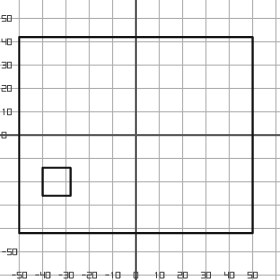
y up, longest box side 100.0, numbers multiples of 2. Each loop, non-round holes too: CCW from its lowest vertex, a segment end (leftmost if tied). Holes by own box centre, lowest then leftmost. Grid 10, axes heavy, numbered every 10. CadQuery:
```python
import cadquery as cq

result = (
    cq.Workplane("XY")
    .moveTo(-50.0, -42.0)
    .lineTo(50.0, -42.0)
    .lineTo(50.0, 42.0)
    .lineTo(-50.0, 42.0)
    .close()
    .moveTo(-40.0, -26.0)
    .lineTo(-28.0, -26.0)
    .lineTo(-28.0, -14.0)
    .lineTo(-40.0, -14.0)
    .close()
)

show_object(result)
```